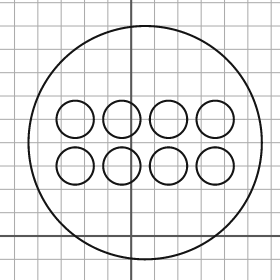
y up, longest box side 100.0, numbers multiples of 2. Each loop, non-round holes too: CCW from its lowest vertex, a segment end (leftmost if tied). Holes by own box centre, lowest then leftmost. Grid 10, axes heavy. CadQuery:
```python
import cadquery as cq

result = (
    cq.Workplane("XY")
    .moveTo(6.0, 40.0)
    .circle(50.0)
    .moveTo(-24.0, 30.0)
    .circle(8.0)
    .moveTo(-4.0, 30.0)
    .circle(8.0)
    .moveTo(16.0, 30.0)
    .circle(8.0)
    .moveTo(36.0, 30.0)
    .circle(8.0)
    .moveTo(-24.0, 50.0)
    .circle(8.0)
    .moveTo(-4.0, 50.0)
    .circle(8.0)
    .moveTo(16.0, 50.0)
    .circle(8.0)
    .moveTo(36.0, 50.0)
    .circle(8.0)
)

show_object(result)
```